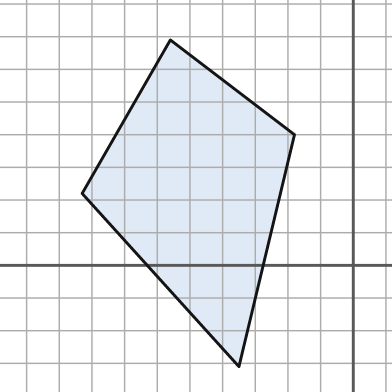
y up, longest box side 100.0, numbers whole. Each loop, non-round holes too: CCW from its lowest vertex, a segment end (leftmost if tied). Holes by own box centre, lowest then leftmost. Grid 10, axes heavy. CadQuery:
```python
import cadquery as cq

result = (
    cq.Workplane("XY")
    .moveTo(-35.0, -31.0)
    .lineTo(-18.0, 40.0)
    .lineTo(-56.0, 69.0)
    .lineTo(-83.0, 22.0)
    .close()
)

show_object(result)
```